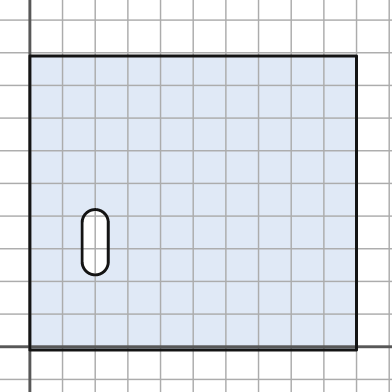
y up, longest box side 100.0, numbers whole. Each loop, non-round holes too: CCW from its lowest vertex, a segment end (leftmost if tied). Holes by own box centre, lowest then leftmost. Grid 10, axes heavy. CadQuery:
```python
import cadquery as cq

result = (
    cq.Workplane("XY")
    .moveTo(0.0, -1.0)
    .lineTo(100.0, -1.0)
    .lineTo(100.0, 89.0)
    .lineTo(0.0, 89.0)
    .close()
    .moveTo(16.0, 26.0)
    .threePointArc((20.0, 22.0), (24.0, 26.0))
    .lineTo(24.0, 38.0)
    .threePointArc((20.0, 42.0), (16.0, 38.0))
    .close()
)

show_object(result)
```